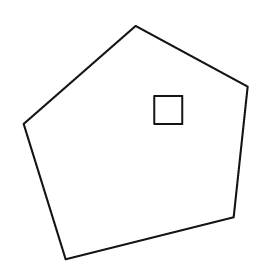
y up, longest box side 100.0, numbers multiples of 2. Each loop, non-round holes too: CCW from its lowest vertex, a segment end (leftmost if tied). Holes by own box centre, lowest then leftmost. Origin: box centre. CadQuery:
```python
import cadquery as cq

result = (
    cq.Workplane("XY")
    .moveTo(-30.0, -50.0)
    .lineTo(42.0, -32.0)
    .lineTo(48.0, 24.0)
    .lineTo(0.0, 50.0)
    .lineTo(-48.0, 8.0)
    .close()
    .moveTo(8.0, 8.0)
    .lineTo(20.0, 8.0)
    .lineTo(20.0, 20.0)
    .lineTo(8.0, 20.0)
    .close()
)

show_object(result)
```